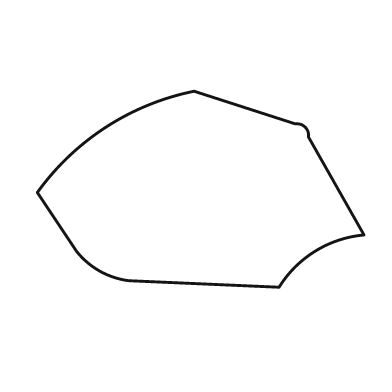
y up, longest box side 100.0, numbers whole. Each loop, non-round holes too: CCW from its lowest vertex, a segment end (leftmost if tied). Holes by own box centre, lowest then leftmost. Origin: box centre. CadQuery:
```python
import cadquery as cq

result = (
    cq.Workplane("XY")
    .moveTo(24.0, -30.0)
    .threePointArc((35.0, -19.0), (50.0, -14.0))
    .lineTo(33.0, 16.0)
    .threePointArc((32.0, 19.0), (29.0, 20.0))
    .lineTo(-2.0, 30.0)
    .threePointArc((-29.0, 19.0), (-50.0, -1.0))
    .lineTo(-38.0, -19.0)
    .threePointArc((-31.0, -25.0), (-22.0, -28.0))
    .close()
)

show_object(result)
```